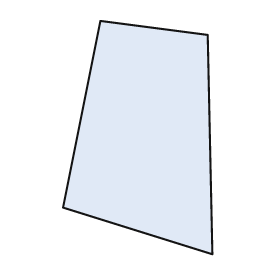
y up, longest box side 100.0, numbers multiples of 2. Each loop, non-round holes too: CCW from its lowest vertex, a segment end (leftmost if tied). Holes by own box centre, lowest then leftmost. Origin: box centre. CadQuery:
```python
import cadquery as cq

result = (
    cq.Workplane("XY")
    .moveTo(32.0, -50.0)
    .lineTo(30.0, 44.0)
    .lineTo(-16.0, 50.0)
    .lineTo(-32.0, -30.0)
    .close()
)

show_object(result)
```